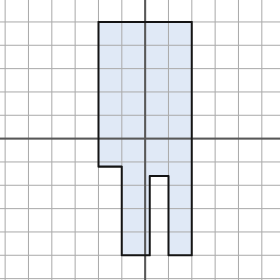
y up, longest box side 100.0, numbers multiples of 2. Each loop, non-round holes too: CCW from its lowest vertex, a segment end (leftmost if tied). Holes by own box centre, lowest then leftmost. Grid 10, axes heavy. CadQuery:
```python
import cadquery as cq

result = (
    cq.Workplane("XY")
    .moveTo(-10.0, -50.0)
    .lineTo(2.0, -50.0)
    .lineTo(2.0, -16.0)
    .lineTo(10.0, -16.0)
    .lineTo(10.0, -50.0)
    .lineTo(20.0, -50.0)
    .lineTo(20.0, 50.0)
    .lineTo(-20.0, 50.0)
    .lineTo(-20.0, -12.0)
    .lineTo(-10.0, -12.0)
    .close()
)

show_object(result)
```